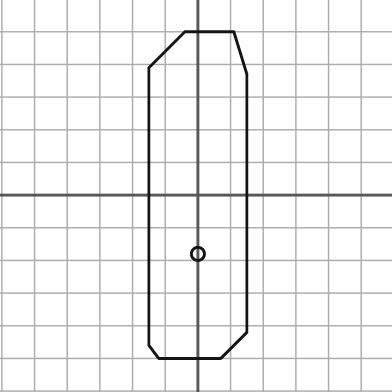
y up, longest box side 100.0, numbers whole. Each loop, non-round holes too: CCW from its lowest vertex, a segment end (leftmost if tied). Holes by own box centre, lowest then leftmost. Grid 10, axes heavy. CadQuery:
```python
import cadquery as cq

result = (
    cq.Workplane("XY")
    .moveTo(-12.0, -50.0)
    .lineTo(7.0, -50.0)
    .lineTo(15.0, -42.0)
    .lineTo(15.0, 37.0)
    .lineTo(11.0, 50.0)
    .lineTo(-4.0, 50.0)
    .lineTo(-15.0, 39.0)
    .lineTo(-15.0, -46.0)
    .close()
    .moveTo(0.0, -18.0)
    .circle(2.0)
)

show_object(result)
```